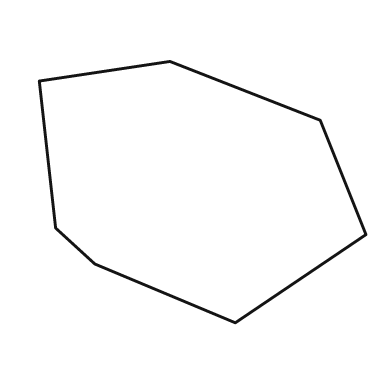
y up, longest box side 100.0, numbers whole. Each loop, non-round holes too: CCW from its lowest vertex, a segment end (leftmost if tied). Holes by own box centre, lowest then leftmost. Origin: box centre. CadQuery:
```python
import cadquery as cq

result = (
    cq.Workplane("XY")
    .moveTo(10.0, -40.0)
    .lineTo(50.0, -13.0)
    .lineTo(36.0, 22.0)
    .lineTo(-10.0, 40.0)
    .lineTo(-50.0, 34.0)
    .lineTo(-45.0, -11.0)
    .lineTo(-33.0, -22.0)
    .close()
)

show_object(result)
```